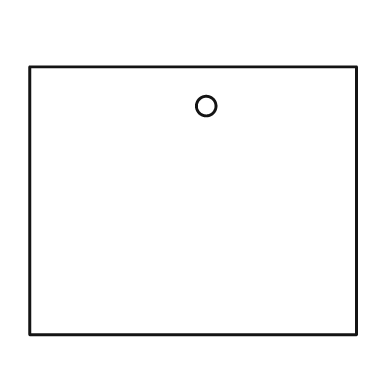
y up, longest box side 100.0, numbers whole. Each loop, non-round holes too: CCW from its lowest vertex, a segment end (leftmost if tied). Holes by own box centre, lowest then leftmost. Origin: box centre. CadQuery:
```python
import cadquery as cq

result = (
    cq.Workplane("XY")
    .moveTo(-50.0, -41.0)
    .lineTo(50.0, -41.0)
    .lineTo(50.0, 41.0)
    .lineTo(-50.0, 41.0)
    .close()
    .moveTo(4.0, 29.0)
    .circle(3.0)
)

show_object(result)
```